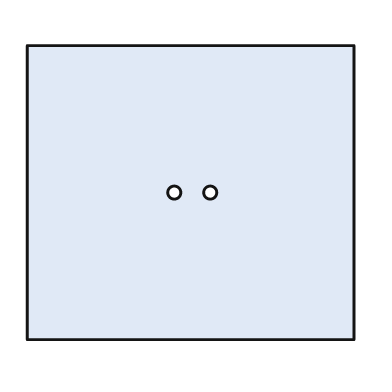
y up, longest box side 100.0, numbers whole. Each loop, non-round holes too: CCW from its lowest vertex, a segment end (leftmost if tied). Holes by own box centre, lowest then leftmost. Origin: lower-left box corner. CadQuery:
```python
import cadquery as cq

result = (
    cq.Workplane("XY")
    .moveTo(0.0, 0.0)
    .lineTo(100.0, 0.0)
    .lineTo(100.0, 90.0)
    .lineTo(0.0, 90.0)
    .close()
    .moveTo(45.0, 45.0)
    .circle(2.0)
    .moveTo(56.0, 45.0)
    .circle(2.0)
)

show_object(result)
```